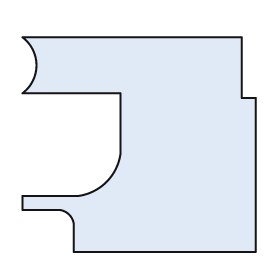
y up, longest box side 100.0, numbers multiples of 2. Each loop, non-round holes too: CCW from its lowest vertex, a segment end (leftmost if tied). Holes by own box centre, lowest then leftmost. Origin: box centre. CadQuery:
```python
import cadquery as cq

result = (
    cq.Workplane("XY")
    .moveTo(-28.0, -46.0)
    .lineTo(50.0, -46.0)
    .lineTo(50.0, 20.0)
    .lineTo(44.0, 20.0)
    .lineTo(44.0, 46.0)
    .lineTo(-50.0, 46.0)
    .threePointArc((-44.0, 34.0), (-50.0, 22.0))
    .lineTo(-8.0, 22.0)
    .lineTo(-8.0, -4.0)
    .threePointArc((-14.0, -16.0), (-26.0, -22.0))
    .lineTo(-50.0, -22.0)
    .lineTo(-50.0, -28.0)
    .lineTo(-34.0, -28.0)
    .threePointArc((-30.0, -30.0), (-28.0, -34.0))
    .close()
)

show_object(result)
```